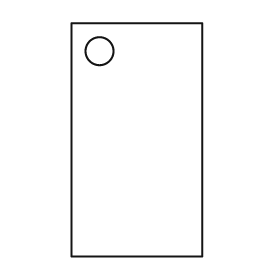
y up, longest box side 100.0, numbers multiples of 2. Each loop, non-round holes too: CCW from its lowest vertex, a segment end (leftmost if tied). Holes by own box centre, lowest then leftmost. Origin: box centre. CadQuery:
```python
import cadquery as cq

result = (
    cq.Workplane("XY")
    .moveTo(-28.0, -50.0)
    .lineTo(28.0, -50.0)
    .lineTo(28.0, 50.0)
    .lineTo(-28.0, 50.0)
    .close()
    .moveTo(-16.0, 38.0)
    .circle(6.0)
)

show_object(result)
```